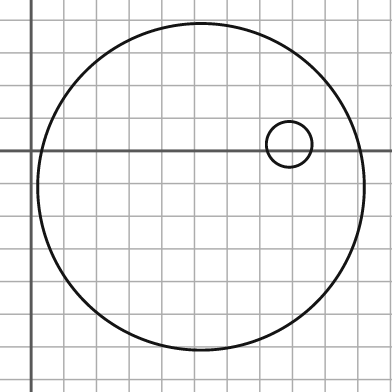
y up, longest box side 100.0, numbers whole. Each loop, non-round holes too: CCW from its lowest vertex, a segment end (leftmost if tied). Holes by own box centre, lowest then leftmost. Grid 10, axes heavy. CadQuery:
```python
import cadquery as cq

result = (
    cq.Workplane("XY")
    .moveTo(52.0, -11.0)
    .circle(50.0)
    .moveTo(79.0, 2.0)
    .circle(7.0)
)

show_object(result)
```